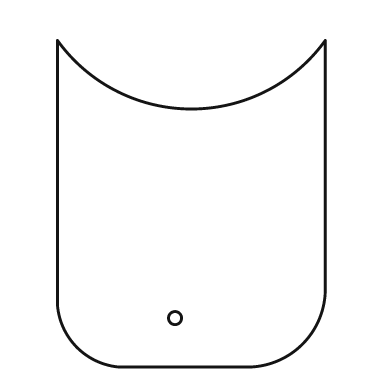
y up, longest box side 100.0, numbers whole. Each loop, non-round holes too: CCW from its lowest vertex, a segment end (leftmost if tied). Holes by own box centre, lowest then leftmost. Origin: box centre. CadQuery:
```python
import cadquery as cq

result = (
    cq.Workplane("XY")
    .moveTo(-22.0, -50.0)
    .lineTo(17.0, -50.0)
    .threePointArc((34.0, -43.0), (41.0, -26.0))
    .lineTo(41.0, 50.0)
    .threePointArc((0.0, 29.0), (-41.0, 50.0))
    .lineTo(-41.0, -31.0)
    .threePointArc((-35.0, -44.0), (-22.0, -50.0))
    .close()
    .moveTo(-5.0, -35.0)
    .circle(2.0)
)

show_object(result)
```